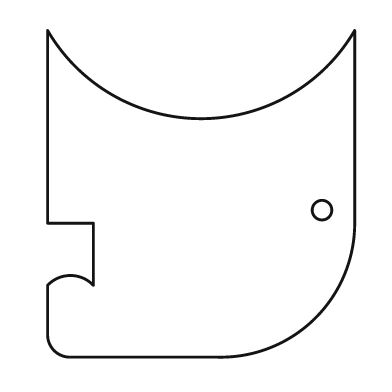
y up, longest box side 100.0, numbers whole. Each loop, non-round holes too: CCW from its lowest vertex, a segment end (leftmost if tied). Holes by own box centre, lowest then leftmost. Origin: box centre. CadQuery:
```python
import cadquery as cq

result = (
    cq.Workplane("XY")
    .moveTo(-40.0, -50.0)
    .lineTo(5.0, -50.0)
    .threePointArc((35.0, -38.0), (47.0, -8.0))
    .lineTo(47.0, 50.0)
    .threePointArc((0.0, 23.0), (-47.0, 50.0))
    .lineTo(-47.0, -9.0)
    .lineTo(-33.0, -9.0)
    .lineTo(-33.0, -28.0)
    .threePointArc((-40.0, -25.0), (-47.0, -28.0))
    .lineTo(-47.0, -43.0)
    .threePointArc((-45.0, -48.0), (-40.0, -50.0))
    .close()
    .moveTo(37.0, -5.0)
    .circle(3.0)
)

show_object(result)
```